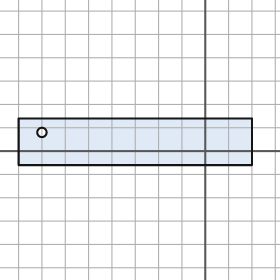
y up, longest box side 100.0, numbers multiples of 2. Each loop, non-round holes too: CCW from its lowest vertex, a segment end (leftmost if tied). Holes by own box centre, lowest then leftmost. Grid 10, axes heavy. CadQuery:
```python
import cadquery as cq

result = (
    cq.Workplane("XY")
    .moveTo(-80.0, -6.0)
    .lineTo(20.0, -6.0)
    .lineTo(20.0, 14.0)
    .lineTo(-80.0, 14.0)
    .close()
    .moveTo(-70.0, 8.0)
    .circle(2.0)
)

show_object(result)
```